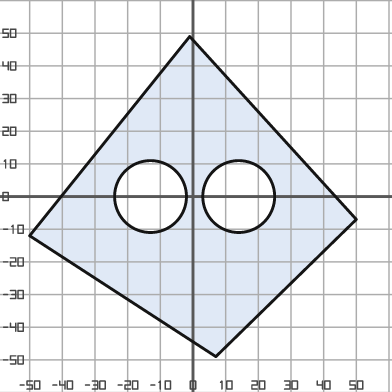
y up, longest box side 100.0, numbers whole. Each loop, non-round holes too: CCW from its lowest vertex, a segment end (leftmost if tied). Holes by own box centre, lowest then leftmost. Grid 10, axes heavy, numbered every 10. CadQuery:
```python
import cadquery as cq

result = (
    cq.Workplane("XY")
    .moveTo(7.0, -49.0)
    .lineTo(50.0, -7.0)
    .lineTo(-1.0, 49.0)
    .lineTo(-50.0, -12.0)
    .close()
    .moveTo(-13.0, 0.0)
    .circle(11.0)
    .moveTo(14.0, 0.0)
    .circle(11.0)
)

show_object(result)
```